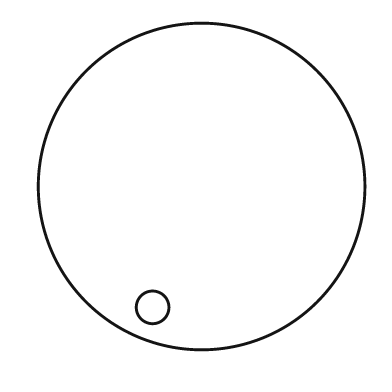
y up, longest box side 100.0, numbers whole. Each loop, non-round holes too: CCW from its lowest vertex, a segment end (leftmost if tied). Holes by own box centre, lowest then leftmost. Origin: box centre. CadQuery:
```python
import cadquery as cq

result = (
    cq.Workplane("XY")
    .moveTo(0.0, 0.0)
    .circle(50.0)
    .moveTo(-15.0, -37.0)
    .circle(5.0)
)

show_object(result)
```